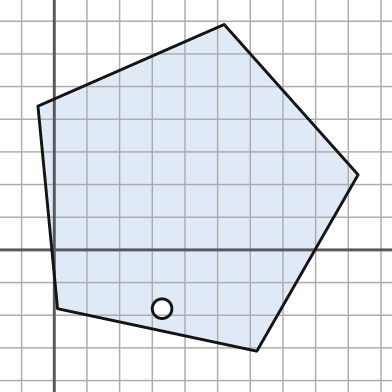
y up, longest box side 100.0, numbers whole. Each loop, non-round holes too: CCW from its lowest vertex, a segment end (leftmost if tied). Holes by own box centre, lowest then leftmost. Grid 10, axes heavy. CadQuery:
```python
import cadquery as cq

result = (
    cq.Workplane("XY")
    .moveTo(62.0, -31.0)
    .lineTo(93.0, 23.0)
    .lineTo(52.0, 69.0)
    .lineTo(-5.0, 44.0)
    .lineTo(1.0, -18.0)
    .close()
    .moveTo(33.0, -18.0)
    .circle(3.0)
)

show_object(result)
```